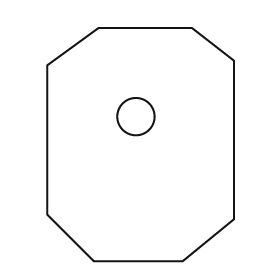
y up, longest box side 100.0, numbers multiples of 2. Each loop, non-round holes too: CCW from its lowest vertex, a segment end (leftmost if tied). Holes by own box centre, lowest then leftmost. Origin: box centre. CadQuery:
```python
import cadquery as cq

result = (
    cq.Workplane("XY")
    .moveTo(-20.0, -50.0)
    .lineTo(18.0, -50.0)
    .lineTo(40.0, -32.0)
    .lineTo(40.0, 36.0)
    .lineTo(22.0, 50.0)
    .lineTo(-18.0, 50.0)
    .lineTo(-40.0, 34.0)
    .lineTo(-40.0, -30.0)
    .close()
    .moveTo(-2.0, 12.0)
    .circle(8.0)
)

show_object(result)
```